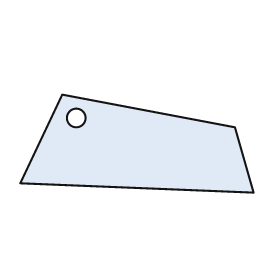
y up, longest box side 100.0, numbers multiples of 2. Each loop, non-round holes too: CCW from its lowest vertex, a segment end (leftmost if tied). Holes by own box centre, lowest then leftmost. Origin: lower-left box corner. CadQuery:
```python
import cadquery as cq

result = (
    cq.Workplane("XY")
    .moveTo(100.0, 0.0)
    .lineTo(92.0, 28.0)
    .lineTo(18.0, 42.0)
    .lineTo(0.0, 4.0)
    .close()
    .moveTo(24.0, 32.0)
    .circle(4.0)
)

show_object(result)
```